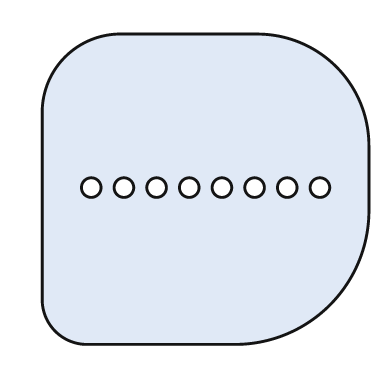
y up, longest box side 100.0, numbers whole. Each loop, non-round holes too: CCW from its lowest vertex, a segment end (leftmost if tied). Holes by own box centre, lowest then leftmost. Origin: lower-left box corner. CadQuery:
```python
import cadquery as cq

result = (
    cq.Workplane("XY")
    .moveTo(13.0, 0.0)
    .lineTo(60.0, 0.0)
    .threePointArc((88.0, 12.0), (100.0, 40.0))
    .lineTo(100.0, 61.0)
    .threePointArc((90.0, 85.0), (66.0, 95.0))
    .lineTo(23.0, 95.0)
    .threePointArc((7.0, 88.0), (0.0, 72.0))
    .lineTo(0.0, 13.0)
    .threePointArc((4.0, 4.0), (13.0, 0.0))
    .close()
    .moveTo(15.0, 48.0)
    .circle(3.0)
    .moveTo(25.0, 48.0)
    .circle(3.0)
    .moveTo(35.0, 48.0)
    .circle(3.0)
    .moveTo(45.0, 48.0)
    .circle(3.0)
    .moveTo(55.0, 48.0)
    .circle(3.0)
    .moveTo(65.0, 48.0)
    .circle(3.0)
    .moveTo(75.0, 48.0)
    .circle(3.0)
    .moveTo(85.0, 48.0)
    .circle(3.0)
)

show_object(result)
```